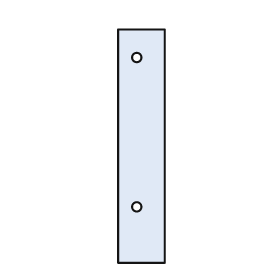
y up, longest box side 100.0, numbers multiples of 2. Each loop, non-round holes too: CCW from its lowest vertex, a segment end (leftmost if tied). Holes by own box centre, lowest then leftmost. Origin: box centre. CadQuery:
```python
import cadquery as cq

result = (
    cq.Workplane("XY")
    .moveTo(-10.0, -50.0)
    .lineTo(10.0, -50.0)
    .lineTo(10.0, 50.0)
    .lineTo(-10.0, 50.0)
    .close()
    .moveTo(-2.0, -26.0)
    .circle(2.0)
    .moveTo(-2.0, 38.0)
    .circle(2.0)
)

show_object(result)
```